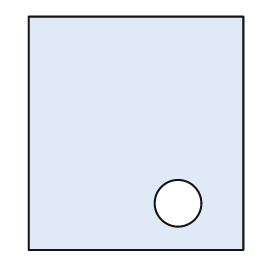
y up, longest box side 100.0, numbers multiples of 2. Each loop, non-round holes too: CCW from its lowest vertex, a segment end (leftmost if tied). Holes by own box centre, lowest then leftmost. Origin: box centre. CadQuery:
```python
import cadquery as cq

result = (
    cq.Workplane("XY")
    .moveTo(-46.0, -50.0)
    .lineTo(46.0, -50.0)
    .lineTo(46.0, 50.0)
    .lineTo(-46.0, 50.0)
    .close()
    .moveTo(18.0, -30.0)
    .circle(10.0)
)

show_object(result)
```